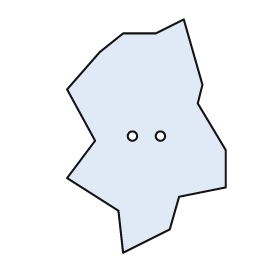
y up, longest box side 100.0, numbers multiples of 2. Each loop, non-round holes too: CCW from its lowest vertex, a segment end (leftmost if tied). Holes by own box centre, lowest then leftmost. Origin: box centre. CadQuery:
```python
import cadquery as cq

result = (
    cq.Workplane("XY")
    .moveTo(-10.0, -50.0)
    .lineTo(10.0, -40.0)
    .lineTo(14.0, -26.0)
    .lineTo(34.0, -22.0)
    .lineTo(34.0, -6.0)
    .lineTo(22.0, 14.0)
    .lineTo(24.0, 22.0)
    .lineTo(16.0, 50.0)
    .lineTo(4.0, 44.0)
    .lineTo(-10.0, 44.0)
    .lineTo(-20.0, 36.0)
    .lineTo(-34.0, 20.0)
    .lineTo(-22.0, -2.0)
    .lineTo(-34.0, -18.0)
    .lineTo(-12.0, -32.0)
    .close()
    .moveTo(-6.0, 0.0)
    .circle(2.0)
    .moveTo(6.0, 0.0)
    .circle(2.0)
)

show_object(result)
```